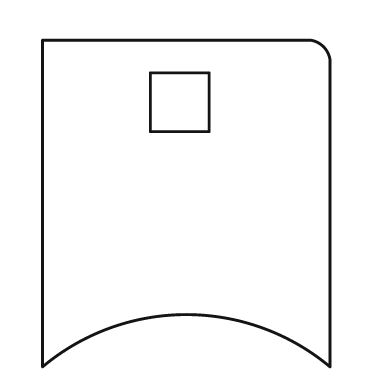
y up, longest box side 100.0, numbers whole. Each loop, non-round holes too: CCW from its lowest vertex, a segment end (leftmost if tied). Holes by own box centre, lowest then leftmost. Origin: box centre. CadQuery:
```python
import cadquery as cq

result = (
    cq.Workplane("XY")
    .moveTo(-44.0, -50.0)
    .threePointArc((0.0, -34.0), (44.0, -50.0))
    .lineTo(44.0, 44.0)
    .threePointArc((42.0, 48.0), (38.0, 50.0))
    .lineTo(-44.0, 50.0)
    .close()
    .moveTo(-11.0, 22.0)
    .lineTo(7.0, 22.0)
    .lineTo(7.0, 40.0)
    .lineTo(-11.0, 40.0)
    .close()
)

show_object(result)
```